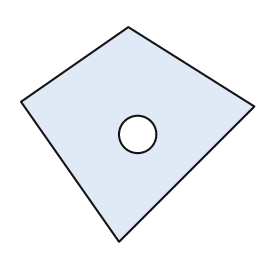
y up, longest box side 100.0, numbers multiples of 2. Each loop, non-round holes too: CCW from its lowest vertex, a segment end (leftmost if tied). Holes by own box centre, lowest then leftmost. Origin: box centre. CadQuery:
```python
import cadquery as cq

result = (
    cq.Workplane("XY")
    .moveTo(-8.0, -46.0)
    .lineTo(50.0, 12.0)
    .lineTo(-4.0, 46.0)
    .lineTo(-50.0, 14.0)
    .close()
    .moveTo(0.0, 0.0)
    .circle(8.0)
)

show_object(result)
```